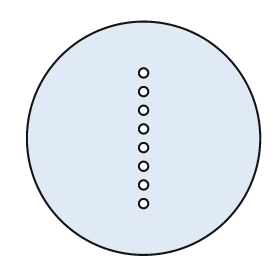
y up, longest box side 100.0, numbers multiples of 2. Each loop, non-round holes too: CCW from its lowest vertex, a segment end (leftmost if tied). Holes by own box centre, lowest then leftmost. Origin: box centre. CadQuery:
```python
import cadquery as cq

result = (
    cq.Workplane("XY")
    .moveTo(0.0, 0.0)
    .circle(50.0)
    .moveTo(0.0, -28.0)
    .circle(2.0)
    .moveTo(0.0, -20.0)
    .circle(2.0)
    .moveTo(0.0, -12.0)
    .circle(2.0)
    .moveTo(0.0, -4.0)
    .circle(2.0)
    .moveTo(0.0, 4.0)
    .circle(2.0)
    .moveTo(0.0, 12.0)
    .circle(2.0)
    .moveTo(0.0, 20.0)
    .circle(2.0)
    .moveTo(0.0, 28.0)
    .circle(2.0)
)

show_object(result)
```